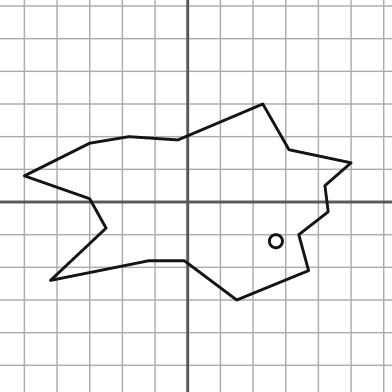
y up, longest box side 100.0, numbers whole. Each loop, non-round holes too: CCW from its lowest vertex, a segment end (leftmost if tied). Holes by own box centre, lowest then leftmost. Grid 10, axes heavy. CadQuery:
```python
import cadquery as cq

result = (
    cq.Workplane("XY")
    .moveTo(15.0, -30.0)
    .lineTo(37.0, -21.0)
    .lineTo(34.0, -10.0)
    .lineTo(43.0, -3.0)
    .lineTo(42.0, 5.0)
    .lineTo(50.0, 12.0)
    .lineTo(31.0, 16.0)
    .lineTo(23.0, 30.0)
    .lineTo(-3.0, 19.0)
    .lineTo(-18.0, 20.0)
    .lineTo(-30.0, 18.0)
    .lineTo(-50.0, 8.0)
    .lineTo(-30.0, 1.0)
    .lineTo(-25.0, -8.0)
    .lineTo(-42.0, -24.0)
    .lineTo(-12.0, -18.0)
    .lineTo(-1.0, -18.0)
    .close()
    .moveTo(27.0, -12.0)
    .circle(2.0)
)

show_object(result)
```